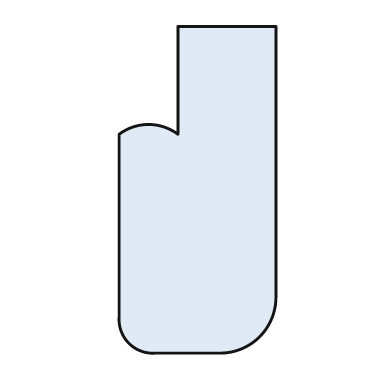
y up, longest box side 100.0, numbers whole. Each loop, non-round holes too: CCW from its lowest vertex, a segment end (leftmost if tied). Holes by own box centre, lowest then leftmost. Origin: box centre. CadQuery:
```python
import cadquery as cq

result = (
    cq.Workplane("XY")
    .moveTo(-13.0, -50.0)
    .lineTo(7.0, -50.0)
    .threePointArc((19.0, -45.0), (24.0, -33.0))
    .lineTo(24.0, 50.0)
    .lineTo(-6.0, 50.0)
    .lineTo(-6.0, 17.0)
    .threePointArc((-15.0, 20.0), (-24.0, 17.0))
    .lineTo(-24.0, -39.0)
    .threePointArc((-21.0, -47.0), (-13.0, -50.0))
    .close()
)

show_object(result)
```